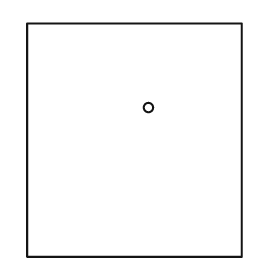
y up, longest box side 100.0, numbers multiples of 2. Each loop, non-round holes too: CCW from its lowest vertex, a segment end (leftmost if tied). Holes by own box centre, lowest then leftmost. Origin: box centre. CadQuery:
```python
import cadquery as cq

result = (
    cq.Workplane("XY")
    .moveTo(-46.0, -50.0)
    .lineTo(46.0, -50.0)
    .lineTo(46.0, 50.0)
    .lineTo(-46.0, 50.0)
    .close()
    .moveTo(6.0, 14.0)
    .circle(2.0)
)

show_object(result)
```